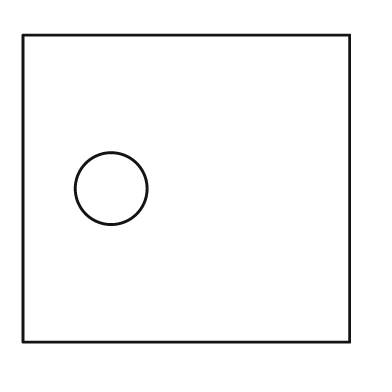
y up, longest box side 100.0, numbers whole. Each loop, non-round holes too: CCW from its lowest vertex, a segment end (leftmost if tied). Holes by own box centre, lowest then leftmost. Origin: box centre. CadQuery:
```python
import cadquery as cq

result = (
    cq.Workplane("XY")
    .moveTo(-50.0, -47.0)
    .lineTo(50.0, -47.0)
    .lineTo(50.0, 47.0)
    .lineTo(-50.0, 47.0)
    .close()
    .moveTo(-23.0, 0.0)
    .circle(11.0)
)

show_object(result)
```